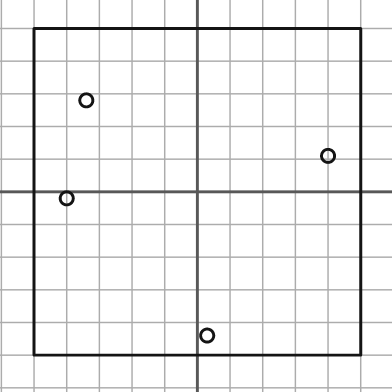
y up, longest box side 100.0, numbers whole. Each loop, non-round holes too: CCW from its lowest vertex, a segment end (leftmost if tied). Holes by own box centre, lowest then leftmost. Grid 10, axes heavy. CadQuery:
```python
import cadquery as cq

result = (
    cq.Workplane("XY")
    .moveTo(-50.0, -50.0)
    .lineTo(50.0, -50.0)
    .lineTo(50.0, 50.0)
    .lineTo(-50.0, 50.0)
    .close()
    .moveTo(3.0, -44.0)
    .circle(2.0)
    .moveTo(-40.0, -2.0)
    .circle(2.0)
    .moveTo(40.0, 11.0)
    .circle(2.0)
    .moveTo(-34.0, 28.0)
    .circle(2.0)
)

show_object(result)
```